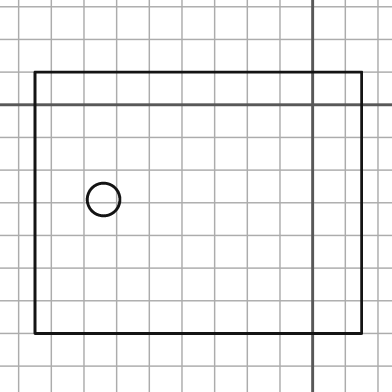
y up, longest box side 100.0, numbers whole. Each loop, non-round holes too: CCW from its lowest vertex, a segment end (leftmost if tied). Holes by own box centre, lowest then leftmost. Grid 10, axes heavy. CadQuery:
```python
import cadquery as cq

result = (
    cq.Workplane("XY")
    .moveTo(-85.0, -70.0)
    .lineTo(15.0, -70.0)
    .lineTo(15.0, 10.0)
    .lineTo(-85.0, 10.0)
    .close()
    .moveTo(-64.0, -29.0)
    .circle(5.0)
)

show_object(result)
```